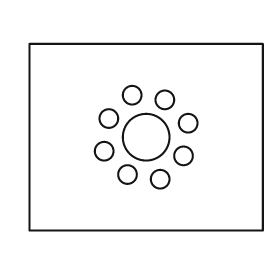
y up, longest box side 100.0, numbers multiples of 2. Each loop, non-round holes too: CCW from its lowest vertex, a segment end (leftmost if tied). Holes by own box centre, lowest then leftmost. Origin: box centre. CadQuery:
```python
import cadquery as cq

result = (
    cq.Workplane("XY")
    .moveTo(-50.0, -40.0)
    .lineTo(50.0, -40.0)
    .lineTo(50.0, 40.0)
    .lineTo(-50.0, 40.0)
    .close()
    .moveTo(6.0, -18.0)
    .circle(4.0)
    .moveTo(-8.0, -16.0)
    .circle(4.0)
    .moveTo(16.0, -8.0)
    .circle(4.0)
    .moveTo(-18.0, -6.0)
    .circle(4.0)
    .moveTo(0.0, 0.0)
    .circle(10.0)
    .moveTo(18.0, 6.0)
    .circle(4.0)
    .moveTo(-16.0, 8.0)
    .circle(4.0)
    .moveTo(8.0, 16.0)
    .circle(4.0)
    .moveTo(-6.0, 18.0)
    .circle(4.0)
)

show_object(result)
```